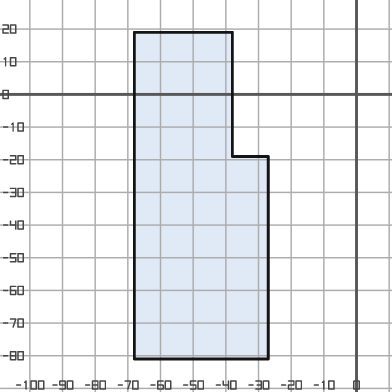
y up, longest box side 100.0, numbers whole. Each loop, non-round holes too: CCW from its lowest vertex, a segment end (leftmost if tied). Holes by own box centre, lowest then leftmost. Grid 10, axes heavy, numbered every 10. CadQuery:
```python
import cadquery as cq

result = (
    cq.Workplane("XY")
    .moveTo(-68.0, -81.0)
    .lineTo(-27.0, -81.0)
    .lineTo(-27.0, -19.0)
    .lineTo(-38.0, -19.0)
    .lineTo(-38.0, 19.0)
    .lineTo(-68.0, 19.0)
    .close()
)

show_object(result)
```